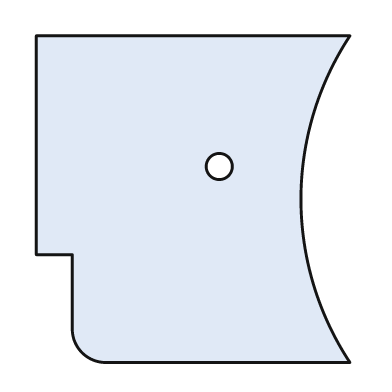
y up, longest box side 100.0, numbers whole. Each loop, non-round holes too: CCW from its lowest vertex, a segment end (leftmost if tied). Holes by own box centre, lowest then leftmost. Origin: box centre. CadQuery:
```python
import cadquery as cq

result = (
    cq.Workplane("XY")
    .moveTo(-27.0, -50.0)
    .lineTo(48.0, -50.0)
    .threePointArc((33.0, 0.0), (48.0, 50.0))
    .lineTo(-48.0, 50.0)
    .lineTo(-48.0, -17.0)
    .lineTo(-37.0, -17.0)
    .lineTo(-37.0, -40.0)
    .threePointArc((-34.0, -47.0), (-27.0, -50.0))
    .close()
    .moveTo(8.0, 10.0)
    .circle(4.0)
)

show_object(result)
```